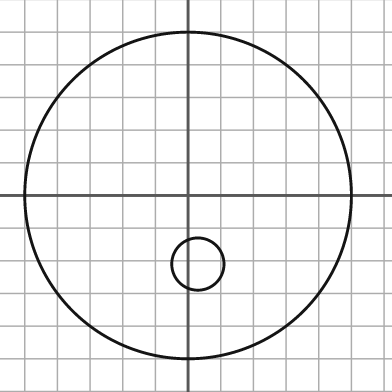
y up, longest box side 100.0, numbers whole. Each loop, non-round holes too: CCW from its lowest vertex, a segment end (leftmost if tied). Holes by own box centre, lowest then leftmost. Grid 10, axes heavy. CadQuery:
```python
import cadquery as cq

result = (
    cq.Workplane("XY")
    .moveTo(0.0, 0.0)
    .circle(50.0)
    .moveTo(3.0, -21.0)
    .circle(8.0)
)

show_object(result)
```